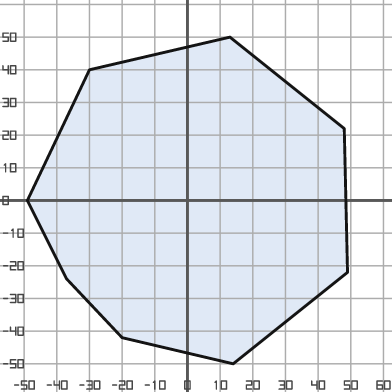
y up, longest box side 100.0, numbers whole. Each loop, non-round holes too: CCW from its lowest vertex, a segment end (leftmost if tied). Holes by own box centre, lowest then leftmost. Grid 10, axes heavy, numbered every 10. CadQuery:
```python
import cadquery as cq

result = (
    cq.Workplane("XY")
    .moveTo(14.0, -50.0)
    .lineTo(49.0, -22.0)
    .lineTo(48.0, 22.0)
    .lineTo(13.0, 50.0)
    .lineTo(-30.0, 40.0)
    .lineTo(-49.0, 0.0)
    .lineTo(-37.0, -24.0)
    .lineTo(-20.0, -42.0)
    .close()
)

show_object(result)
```